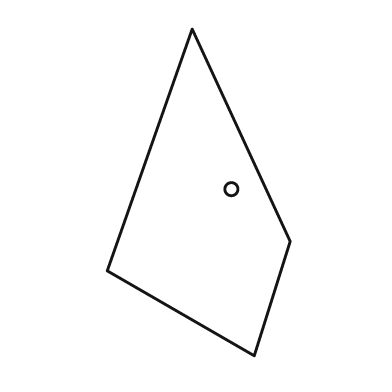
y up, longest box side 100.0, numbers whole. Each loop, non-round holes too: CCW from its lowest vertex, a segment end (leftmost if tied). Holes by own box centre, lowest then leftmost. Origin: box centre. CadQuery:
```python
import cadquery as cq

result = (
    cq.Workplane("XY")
    .moveTo(17.0, -50.0)
    .lineTo(28.0, -15.0)
    .lineTo(-2.0, 50.0)
    .lineTo(-28.0, -24.0)
    .close()
    .moveTo(10.0, 1.0)
    .circle(2.0)
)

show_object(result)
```